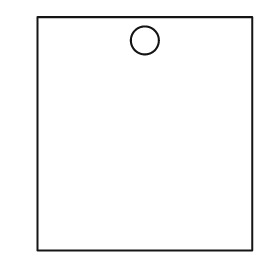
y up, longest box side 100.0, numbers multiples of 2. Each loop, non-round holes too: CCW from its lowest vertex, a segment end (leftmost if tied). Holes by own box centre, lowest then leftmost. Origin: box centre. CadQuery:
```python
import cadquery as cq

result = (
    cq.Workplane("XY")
    .moveTo(-46.0, -50.0)
    .lineTo(46.0, -50.0)
    .lineTo(46.0, 50.0)
    .lineTo(-46.0, 50.0)
    .close()
    .moveTo(0.0, 40.0)
    .circle(6.0)
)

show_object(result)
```